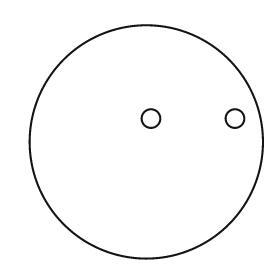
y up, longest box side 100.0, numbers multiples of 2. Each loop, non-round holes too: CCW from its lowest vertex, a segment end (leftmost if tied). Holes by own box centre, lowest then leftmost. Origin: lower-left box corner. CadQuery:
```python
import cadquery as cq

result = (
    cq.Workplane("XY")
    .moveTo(50.0, 50.0)
    .circle(50.0)
    .moveTo(52.0, 60.0)
    .circle(4.0)
    .moveTo(88.0, 60.0)
    .circle(4.0)
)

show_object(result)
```